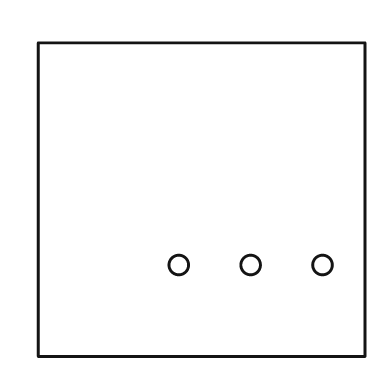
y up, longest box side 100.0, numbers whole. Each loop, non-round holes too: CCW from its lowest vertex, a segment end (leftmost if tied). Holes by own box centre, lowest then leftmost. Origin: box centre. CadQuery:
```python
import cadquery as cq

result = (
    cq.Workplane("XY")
    .moveTo(-50.0, -48.0)
    .lineTo(50.0, -48.0)
    .lineTo(50.0, 48.0)
    .lineTo(-50.0, 48.0)
    .close()
    .moveTo(-7.0, -20.0)
    .circle(3.0)
    .moveTo(15.0, -20.0)
    .circle(3.0)
    .moveTo(37.0, -20.0)
    .circle(3.0)
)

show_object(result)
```